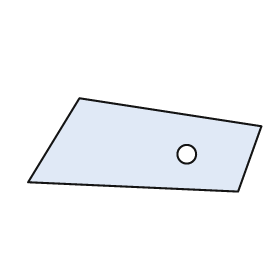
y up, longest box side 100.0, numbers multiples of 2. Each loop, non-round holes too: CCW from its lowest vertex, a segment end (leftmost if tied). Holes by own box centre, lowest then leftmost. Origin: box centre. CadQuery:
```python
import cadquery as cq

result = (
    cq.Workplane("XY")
    .moveTo(40.0, -20.0)
    .lineTo(50.0, 8.0)
    .lineTo(-28.0, 20.0)
    .lineTo(-50.0, -16.0)
    .close()
    .moveTo(18.0, -4.0)
    .circle(4.0)
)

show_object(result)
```